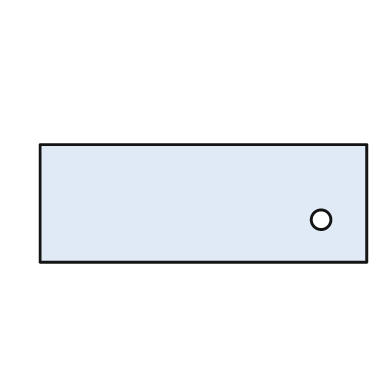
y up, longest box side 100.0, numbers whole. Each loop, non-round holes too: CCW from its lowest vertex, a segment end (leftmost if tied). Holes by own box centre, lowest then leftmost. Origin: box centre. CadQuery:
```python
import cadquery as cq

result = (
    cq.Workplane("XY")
    .moveTo(-50.0, -18.0)
    .lineTo(50.0, -18.0)
    .lineTo(50.0, 18.0)
    .lineTo(-50.0, 18.0)
    .close()
    .moveTo(36.0, -5.0)
    .circle(3.0)
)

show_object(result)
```